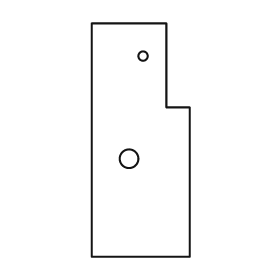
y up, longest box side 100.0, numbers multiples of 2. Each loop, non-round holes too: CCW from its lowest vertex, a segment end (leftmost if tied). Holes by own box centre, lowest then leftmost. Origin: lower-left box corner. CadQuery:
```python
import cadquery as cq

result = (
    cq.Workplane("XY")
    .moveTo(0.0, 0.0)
    .lineTo(42.0, 0.0)
    .lineTo(42.0, 64.0)
    .lineTo(32.0, 64.0)
    .lineTo(32.0, 100.0)
    .lineTo(0.0, 100.0)
    .close()
    .moveTo(16.0, 42.0)
    .circle(4.0)
    .moveTo(22.0, 86.0)
    .circle(2.0)
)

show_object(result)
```